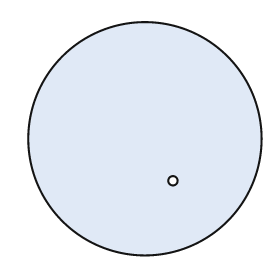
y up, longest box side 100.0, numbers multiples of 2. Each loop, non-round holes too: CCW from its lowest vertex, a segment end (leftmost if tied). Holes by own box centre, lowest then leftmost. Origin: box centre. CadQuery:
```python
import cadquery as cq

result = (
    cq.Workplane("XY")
    .moveTo(0.0, 0.0)
    .circle(50.0)
    .moveTo(12.0, -18.0)
    .circle(2.0)
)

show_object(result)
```